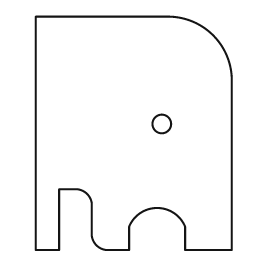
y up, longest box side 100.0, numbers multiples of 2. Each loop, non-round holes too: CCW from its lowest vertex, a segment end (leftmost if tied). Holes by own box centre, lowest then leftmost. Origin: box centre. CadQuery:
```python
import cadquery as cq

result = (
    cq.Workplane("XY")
    .moveTo(-42.0, -50.0)
    .lineTo(-32.0, -50.0)
    .lineTo(-32.0, -24.0)
    .lineTo(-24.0, -24.0)
    .threePointArc((-20.0, -26.0), (-18.0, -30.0))
    .lineTo(-18.0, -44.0)
    .threePointArc((-16.0, -48.0), (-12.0, -50.0))
    .lineTo(-2.0, -50.0)
    .lineTo(-2.0, -40.0)
    .threePointArc((10.0, -32.0), (22.0, -40.0))
    .lineTo(22.0, -50.0)
    .lineTo(42.0, -50.0)
    .lineTo(42.0, 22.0)
    .threePointArc((34.0, 42.0), (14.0, 50.0))
    .lineTo(-42.0, 50.0)
    .close()
    .moveTo(12.0, 4.0)
    .circle(4.0)
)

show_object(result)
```